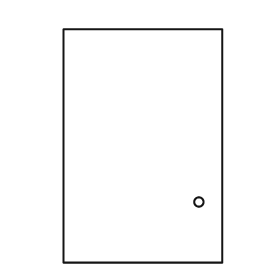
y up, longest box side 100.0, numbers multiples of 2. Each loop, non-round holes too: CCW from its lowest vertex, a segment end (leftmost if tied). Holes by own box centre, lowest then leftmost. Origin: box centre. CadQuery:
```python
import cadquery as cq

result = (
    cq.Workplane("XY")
    .moveTo(-34.0, -50.0)
    .lineTo(34.0, -50.0)
    .lineTo(34.0, 50.0)
    .lineTo(-34.0, 50.0)
    .close()
    .moveTo(24.0, -24.0)
    .circle(2.0)
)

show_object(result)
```